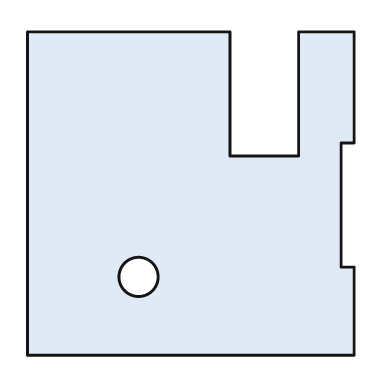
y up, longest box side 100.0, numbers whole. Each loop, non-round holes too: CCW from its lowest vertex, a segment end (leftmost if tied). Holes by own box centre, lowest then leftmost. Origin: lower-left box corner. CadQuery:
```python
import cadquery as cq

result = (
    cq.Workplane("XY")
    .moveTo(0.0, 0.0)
    .lineTo(100.0, 0.0)
    .lineTo(100.0, 27.0)
    .lineTo(96.0, 27.0)
    .lineTo(96.0, 65.0)
    .lineTo(100.0, 65.0)
    .lineTo(100.0, 99.0)
    .lineTo(83.0, 99.0)
    .lineTo(83.0, 61.0)
    .lineTo(62.0, 61.0)
    .lineTo(62.0, 99.0)
    .lineTo(0.0, 99.0)
    .close()
    .moveTo(34.0, 24.0)
    .circle(6.0)
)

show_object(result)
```